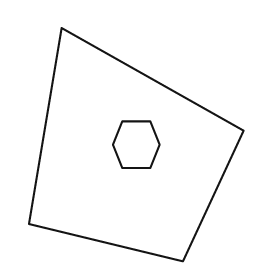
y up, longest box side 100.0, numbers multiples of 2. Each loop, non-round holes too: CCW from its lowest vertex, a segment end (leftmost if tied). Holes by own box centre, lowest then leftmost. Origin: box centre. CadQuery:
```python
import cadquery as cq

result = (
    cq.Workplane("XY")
    .moveTo(20.0, -50.0)
    .lineTo(46.0, 6.0)
    .lineTo(-32.0, 50.0)
    .lineTo(-46.0, -34.0)
    .close()
    .moveTo(-6.0, -10.0)
    .lineTo(6.0, -10.0)
    .lineTo(10.0, 0.0)
    .lineTo(6.0, 10.0)
    .lineTo(-6.0, 10.0)
    .lineTo(-10.0, 0.0)
    .close()
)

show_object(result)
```